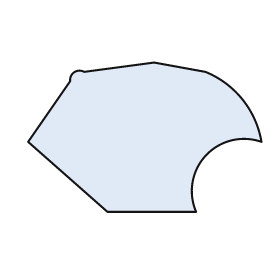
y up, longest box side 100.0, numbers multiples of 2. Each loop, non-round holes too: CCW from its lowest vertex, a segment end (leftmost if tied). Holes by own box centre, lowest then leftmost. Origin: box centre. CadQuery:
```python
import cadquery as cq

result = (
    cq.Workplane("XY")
    .moveTo(-16.0, -32.0)
    .lineTo(22.0, -32.0)
    .threePointArc((26.0, -8.0), (50.0, -2.0))
    .threePointArc((42.0, 16.0), (26.0, 28.0))
    .lineTo(4.0, 32.0)
    .lineTo(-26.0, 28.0)
    .threePointArc((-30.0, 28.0), (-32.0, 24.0))
    .lineTo(-50.0, -2.0)
    .close()
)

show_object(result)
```